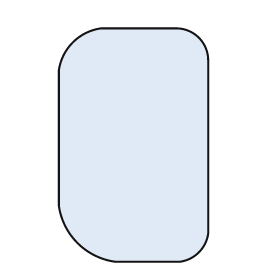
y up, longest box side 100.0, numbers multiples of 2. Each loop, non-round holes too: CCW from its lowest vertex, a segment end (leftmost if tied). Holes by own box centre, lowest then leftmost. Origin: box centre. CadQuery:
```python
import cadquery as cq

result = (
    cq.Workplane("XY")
    .moveTo(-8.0, -50.0)
    .lineTo(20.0, -50.0)
    .threePointArc((28.0, -46.0), (32.0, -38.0))
    .lineTo(32.0, 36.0)
    .threePointArc((28.0, 46.0), (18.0, 50.0))
    .lineTo(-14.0, 50.0)
    .threePointArc((-26.0, 44.0), (-32.0, 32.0))
    .lineTo(-32.0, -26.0)
    .threePointArc((-24.0, -42.0), (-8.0, -50.0))
    .close()
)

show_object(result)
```